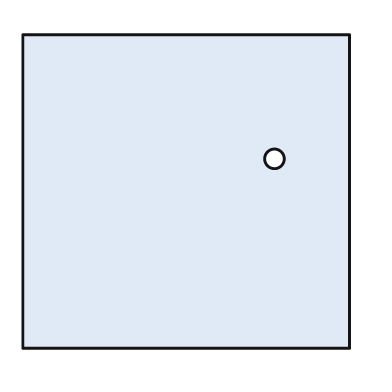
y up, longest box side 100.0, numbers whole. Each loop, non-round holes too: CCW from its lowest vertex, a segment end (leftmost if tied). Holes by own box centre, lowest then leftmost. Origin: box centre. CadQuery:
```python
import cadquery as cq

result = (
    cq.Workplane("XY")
    .moveTo(-50.0, -48.0)
    .lineTo(50.0, -48.0)
    .lineTo(50.0, 48.0)
    .lineTo(-50.0, 48.0)
    .close()
    .moveTo(27.0, 10.0)
    .circle(3.0)
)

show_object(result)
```